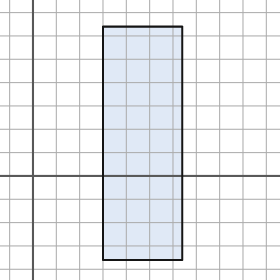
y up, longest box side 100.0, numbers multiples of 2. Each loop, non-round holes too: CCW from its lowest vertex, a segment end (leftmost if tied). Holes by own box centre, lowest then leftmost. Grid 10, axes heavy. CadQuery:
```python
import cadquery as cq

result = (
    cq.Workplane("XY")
    .moveTo(30.0, -36.0)
    .lineTo(64.0, -36.0)
    .lineTo(64.0, 64.0)
    .lineTo(30.0, 64.0)
    .close()
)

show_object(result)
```